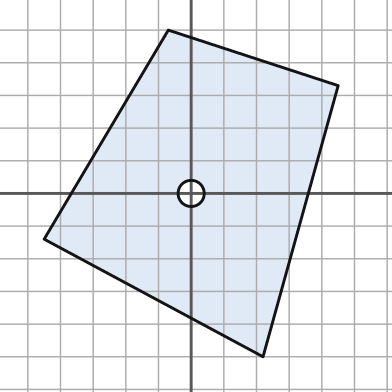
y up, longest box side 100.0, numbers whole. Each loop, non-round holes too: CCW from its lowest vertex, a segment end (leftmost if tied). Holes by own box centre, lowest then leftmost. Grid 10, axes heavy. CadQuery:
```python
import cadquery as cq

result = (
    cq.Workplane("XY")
    .moveTo(22.0, -50.0)
    .lineTo(45.0, 33.0)
    .lineTo(-7.0, 50.0)
    .lineTo(-45.0, -14.0)
    .close()
    .moveTo(0.0, 0.0)
    .circle(4.0)
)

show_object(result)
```